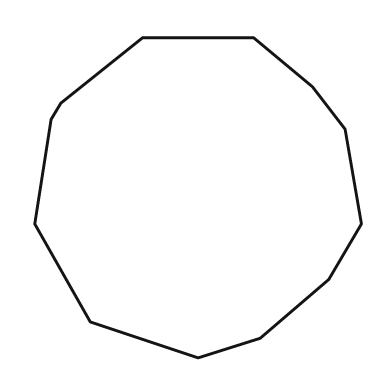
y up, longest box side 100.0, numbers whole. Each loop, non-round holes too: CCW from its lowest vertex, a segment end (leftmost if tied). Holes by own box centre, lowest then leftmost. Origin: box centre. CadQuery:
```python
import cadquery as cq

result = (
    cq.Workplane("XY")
    .moveTo(0.0, -49.0)
    .lineTo(19.0, -43.0)
    .lineTo(40.0, -25.0)
    .lineTo(50.0, -8.0)
    .lineTo(45.0, 21.0)
    .lineTo(35.0, 34.0)
    .lineTo(17.0, 49.0)
    .lineTo(-17.0, 49.0)
    .lineTo(-42.0, 29.0)
    .lineTo(-45.0, 24.0)
    .lineTo(-50.0, -8.0)
    .lineTo(-33.0, -38.0)
    .close()
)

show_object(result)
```